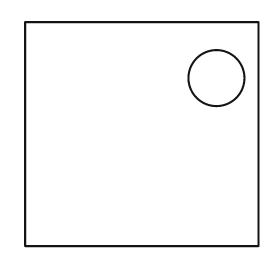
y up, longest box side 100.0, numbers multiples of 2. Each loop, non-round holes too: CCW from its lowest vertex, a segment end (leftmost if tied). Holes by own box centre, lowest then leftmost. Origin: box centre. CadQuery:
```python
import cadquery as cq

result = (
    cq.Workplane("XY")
    .moveTo(-50.0, -48.0)
    .lineTo(50.0, -48.0)
    .lineTo(50.0, 48.0)
    .lineTo(-50.0, 48.0)
    .close()
    .moveTo(32.0, 24.0)
    .circle(12.0)
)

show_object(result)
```